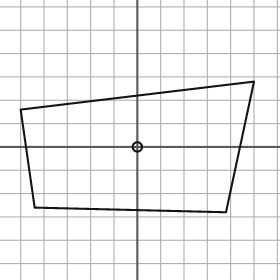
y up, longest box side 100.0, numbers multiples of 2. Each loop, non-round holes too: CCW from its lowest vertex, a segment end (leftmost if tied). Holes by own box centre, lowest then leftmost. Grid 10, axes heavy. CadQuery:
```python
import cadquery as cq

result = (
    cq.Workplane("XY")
    .moveTo(38.0, -28.0)
    .lineTo(50.0, 28.0)
    .lineTo(-50.0, 16.0)
    .lineTo(-44.0, -26.0)
    .close()
    .moveTo(0.0, 0.0)
    .circle(2.0)
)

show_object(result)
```